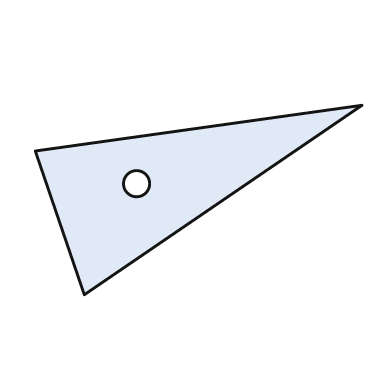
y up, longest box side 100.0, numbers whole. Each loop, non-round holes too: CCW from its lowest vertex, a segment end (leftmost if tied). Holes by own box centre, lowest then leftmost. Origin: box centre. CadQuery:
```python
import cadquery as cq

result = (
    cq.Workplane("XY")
    .moveTo(-35.0, -29.0)
    .lineTo(50.0, 29.0)
    .lineTo(-50.0, 15.0)
    .close()
    .moveTo(-19.0, 5.0)
    .circle(4.0)
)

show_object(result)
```